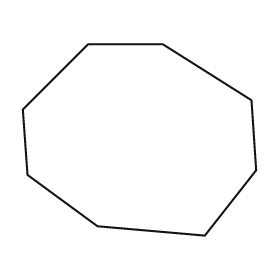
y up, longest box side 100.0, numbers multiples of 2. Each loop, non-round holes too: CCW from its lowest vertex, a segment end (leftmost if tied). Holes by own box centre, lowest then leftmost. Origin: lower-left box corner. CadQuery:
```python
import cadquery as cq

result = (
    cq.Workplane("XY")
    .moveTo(78.0, 0.0)
    .lineTo(100.0, 28.0)
    .lineTo(98.0, 58.0)
    .lineTo(60.0, 82.0)
    .lineTo(28.0, 82.0)
    .lineTo(0.0, 54.0)
    .lineTo(2.0, 26.0)
    .lineTo(32.0, 4.0)
    .close()
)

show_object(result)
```